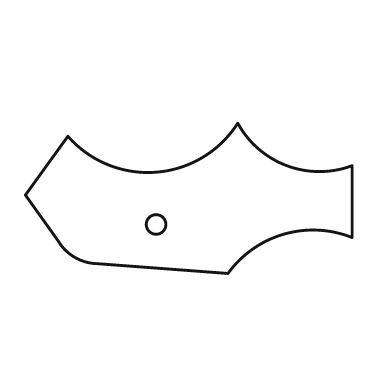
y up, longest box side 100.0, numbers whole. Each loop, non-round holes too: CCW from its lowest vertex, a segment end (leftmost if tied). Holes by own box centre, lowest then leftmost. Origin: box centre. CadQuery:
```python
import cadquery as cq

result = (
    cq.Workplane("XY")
    .moveTo(12.0, -23.0)
    .threePointArc((29.0, -11.0), (50.0, -12.0))
    .lineTo(50.0, 10.0)
    .threePointArc((30.0, 10.0), (15.0, 23.0))
    .threePointArc((-10.0, 8.0), (-37.0, 19.0))
    .lineTo(-50.0, 1.0)
    .lineTo(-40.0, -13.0)
    .threePointArc((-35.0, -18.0), (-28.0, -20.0))
    .close()
    .moveTo(-10.0, -8.0)
    .circle(3.0)
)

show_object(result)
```